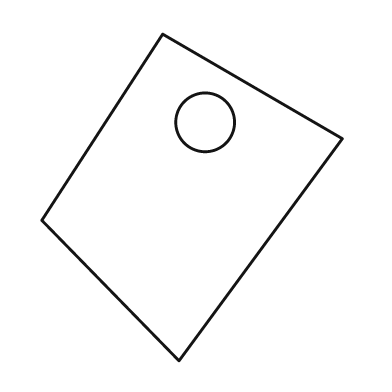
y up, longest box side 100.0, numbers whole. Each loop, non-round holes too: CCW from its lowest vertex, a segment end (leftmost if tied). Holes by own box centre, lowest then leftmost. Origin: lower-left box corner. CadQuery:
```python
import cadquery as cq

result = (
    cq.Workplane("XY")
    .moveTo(42.0, 0.0)
    .lineTo(92.0, 68.0)
    .lineTo(37.0, 100.0)
    .lineTo(0.0, 43.0)
    .close()
    .moveTo(50.0, 73.0)
    .circle(9.0)
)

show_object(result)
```